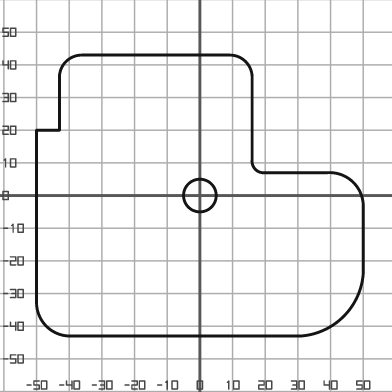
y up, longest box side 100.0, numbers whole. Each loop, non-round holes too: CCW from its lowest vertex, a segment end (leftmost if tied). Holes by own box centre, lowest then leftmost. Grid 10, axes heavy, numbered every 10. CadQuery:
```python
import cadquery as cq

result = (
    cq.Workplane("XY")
    .moveTo(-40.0, -43.0)
    .lineTo(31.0, -43.0)
    .threePointArc((44.0, -37.0), (50.0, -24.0))
    .lineTo(50.0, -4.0)
    .threePointArc((47.0, 4.0), (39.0, 7.0))
    .lineTo(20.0, 7.0)
    .threePointArc((17.0, 8.0), (16.0, 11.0))
    .lineTo(16.0, 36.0)
    .threePointArc((14.0, 41.0), (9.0, 43.0))
    .lineTo(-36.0, 43.0)
    .threePointArc((-41.0, 41.0), (-43.0, 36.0))
    .lineTo(-43.0, 20.0)
    .lineTo(-50.0, 20.0)
    .lineTo(-50.0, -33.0)
    .threePointArc((-47.0, -40.0), (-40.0, -43.0))
    .close()
    .moveTo(0.0, 0.0)
    .circle(5.0)
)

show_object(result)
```